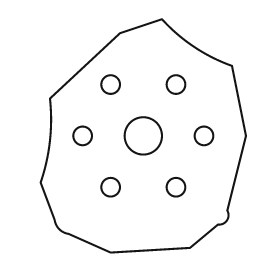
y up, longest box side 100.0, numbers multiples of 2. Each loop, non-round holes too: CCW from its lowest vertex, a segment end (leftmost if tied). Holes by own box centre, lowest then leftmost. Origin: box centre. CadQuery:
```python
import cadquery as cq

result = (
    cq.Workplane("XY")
    .moveTo(-14.0, -50.0)
    .lineTo(20.0, -48.0)
    .lineTo(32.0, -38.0)
    .threePointArc((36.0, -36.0), (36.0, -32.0))
    .lineTo(44.0, 0.0)
    .lineTo(38.0, 30.0)
    .threePointArc((22.0, 38.0), (8.0, 50.0))
    .lineTo(-10.0, 44.0)
    .lineTo(-40.0, 16.0)
    .threePointArc((-40.0, -2.0), (-44.0, -20.0))
    .lineTo(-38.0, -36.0)
    .threePointArc((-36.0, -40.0), (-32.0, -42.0))
    .close()
    .moveTo(-14.0, -22.0)
    .circle(4.0)
    .moveTo(14.0, -22.0)
    .circle(4.0)
    .moveTo(-26.0, 0.0)
    .circle(4.0)
    .moveTo(0.0, 0.0)
    .circle(8.0)
    .moveTo(26.0, 0.0)
    .circle(4.0)
    .moveTo(-14.0, 22.0)
    .circle(4.0)
    .moveTo(14.0, 22.0)
    .circle(4.0)
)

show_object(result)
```